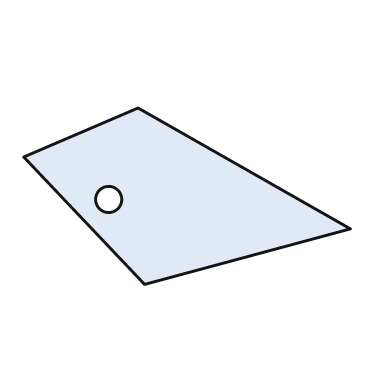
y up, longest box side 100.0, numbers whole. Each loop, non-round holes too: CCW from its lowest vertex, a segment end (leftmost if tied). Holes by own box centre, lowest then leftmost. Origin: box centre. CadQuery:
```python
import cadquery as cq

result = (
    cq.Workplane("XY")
    .moveTo(-13.0, -27.0)
    .lineTo(50.0, -10.0)
    .lineTo(-15.0, 27.0)
    .lineTo(-50.0, 12.0)
    .close()
    .moveTo(-24.0, -1.0)
    .circle(4.0)
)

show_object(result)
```